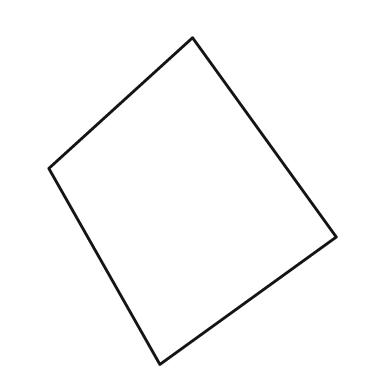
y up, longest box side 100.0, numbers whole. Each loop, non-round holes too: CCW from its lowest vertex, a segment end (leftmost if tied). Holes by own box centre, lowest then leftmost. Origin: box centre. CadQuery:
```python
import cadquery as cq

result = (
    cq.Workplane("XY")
    .moveTo(-10.0, -50.0)
    .lineTo(44.0, -11.0)
    .lineTo(0.0, 50.0)
    .lineTo(-44.0, 10.0)
    .close()
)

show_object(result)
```